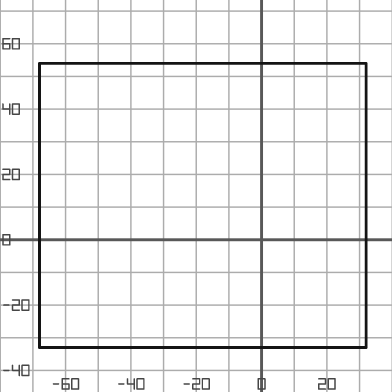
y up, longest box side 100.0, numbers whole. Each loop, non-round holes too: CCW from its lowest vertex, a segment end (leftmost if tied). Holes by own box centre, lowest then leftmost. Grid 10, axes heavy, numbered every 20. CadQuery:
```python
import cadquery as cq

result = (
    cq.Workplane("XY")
    .moveTo(-68.0, -33.0)
    .lineTo(32.0, -33.0)
    .lineTo(32.0, 54.0)
    .lineTo(-68.0, 54.0)
    .close()
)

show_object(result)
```